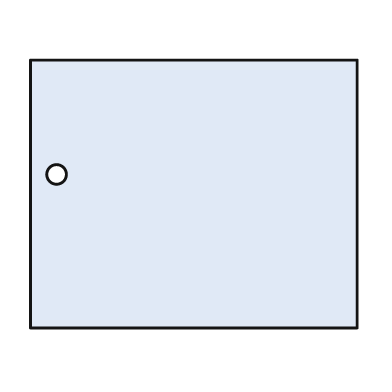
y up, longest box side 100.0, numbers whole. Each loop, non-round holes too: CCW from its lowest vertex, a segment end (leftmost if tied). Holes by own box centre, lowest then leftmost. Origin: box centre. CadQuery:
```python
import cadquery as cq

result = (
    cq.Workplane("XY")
    .moveTo(-50.0, -41.0)
    .lineTo(50.0, -41.0)
    .lineTo(50.0, 41.0)
    .lineTo(-50.0, 41.0)
    .close()
    .moveTo(-42.0, 6.0)
    .circle(3.0)
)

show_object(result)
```